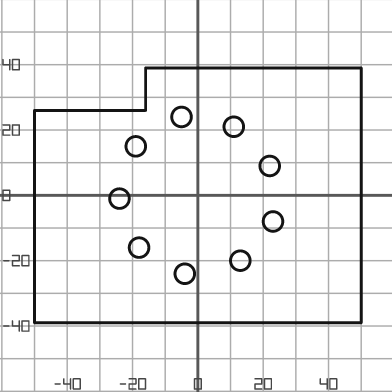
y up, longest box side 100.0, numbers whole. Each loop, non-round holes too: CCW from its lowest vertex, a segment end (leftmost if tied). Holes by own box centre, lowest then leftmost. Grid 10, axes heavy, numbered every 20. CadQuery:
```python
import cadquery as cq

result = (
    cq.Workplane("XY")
    .moveTo(-50.0, -39.0)
    .lineTo(50.0, -39.0)
    .lineTo(50.0, 39.0)
    .lineTo(-16.0, 39.0)
    .lineTo(-16.0, 26.0)
    .lineTo(-50.0, 26.0)
    .close()
    .moveTo(-4.0, -24.0)
    .circle(3.0)
    .moveTo(13.0, -20.0)
    .circle(3.0)
    .moveTo(-18.0, -16.0)
    .circle(3.0)
    .moveTo(23.0, -8.0)
    .circle(3.0)
    .moveTo(-24.0, -1.0)
    .circle(3.0)
    .moveTo(22.0, 9.0)
    .circle(3.0)
    .moveTo(-19.0, 15.0)
    .circle(3.0)
    .moveTo(11.0, 21.0)
    .circle(3.0)
    .moveTo(-5.0, 24.0)
    .circle(3.0)
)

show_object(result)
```